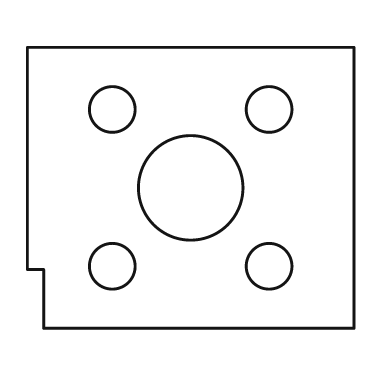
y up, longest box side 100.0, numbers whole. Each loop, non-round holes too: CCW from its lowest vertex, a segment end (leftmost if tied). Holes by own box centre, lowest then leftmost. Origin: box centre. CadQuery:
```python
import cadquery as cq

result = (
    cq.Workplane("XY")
    .moveTo(-45.0, -43.0)
    .lineTo(50.0, -43.0)
    .lineTo(50.0, 43.0)
    .lineTo(-50.0, 43.0)
    .lineTo(-50.0, -25.0)
    .lineTo(-45.0, -25.0)
    .close()
    .moveTo(-24.0, -24.0)
    .circle(7.0)
    .moveTo(24.0, -24.0)
    .circle(7.0)
    .moveTo(0.0, 0.0)
    .circle(16.0)
    .moveTo(-24.0, 24.0)
    .circle(7.0)
    .moveTo(24.0, 24.0)
    .circle(7.0)
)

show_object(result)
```